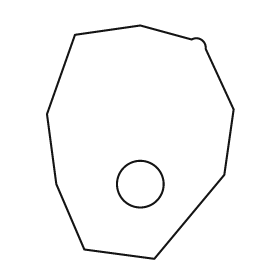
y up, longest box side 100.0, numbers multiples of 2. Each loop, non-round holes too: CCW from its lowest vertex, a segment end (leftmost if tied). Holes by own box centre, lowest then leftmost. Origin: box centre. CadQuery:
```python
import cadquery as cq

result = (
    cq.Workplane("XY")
    .moveTo(6.0, -50.0)
    .lineTo(36.0, -14.0)
    .lineTo(40.0, 14.0)
    .lineTo(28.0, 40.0)
    .threePointArc((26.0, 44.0), (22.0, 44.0))
    .lineTo(0.0, 50.0)
    .lineTo(-28.0, 46.0)
    .lineTo(-40.0, 12.0)
    .lineTo(-36.0, -18.0)
    .lineTo(-24.0, -46.0)
    .close()
    .moveTo(0.0, -18.0)
    .circle(10.0)
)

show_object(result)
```